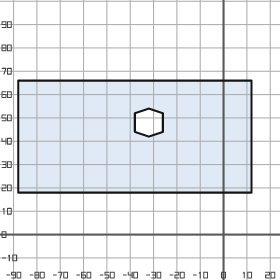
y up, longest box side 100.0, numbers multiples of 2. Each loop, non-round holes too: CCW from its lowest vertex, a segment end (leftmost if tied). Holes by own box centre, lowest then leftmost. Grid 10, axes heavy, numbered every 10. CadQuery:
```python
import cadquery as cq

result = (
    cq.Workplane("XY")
    .moveTo(-88.0, 18.0)
    .lineTo(12.0, 18.0)
    .lineTo(12.0, 66.0)
    .lineTo(-88.0, 66.0)
    .close()
    .moveTo(-32.0, 42.0)
    .lineTo(-26.0, 44.0)
    .lineTo(-26.0, 52.0)
    .lineTo(-32.0, 54.0)
    .lineTo(-38.0, 52.0)
    .lineTo(-38.0, 44.0)
    .close()
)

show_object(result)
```